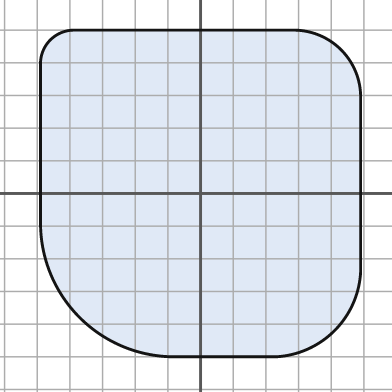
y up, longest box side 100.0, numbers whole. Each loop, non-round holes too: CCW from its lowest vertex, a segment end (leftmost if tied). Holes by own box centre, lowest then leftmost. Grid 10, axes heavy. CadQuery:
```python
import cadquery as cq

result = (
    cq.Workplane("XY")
    .moveTo(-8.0, -50.0)
    .lineTo(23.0, -50.0)
    .threePointArc((41.0, -42.0), (49.0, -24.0))
    .lineTo(49.0, 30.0)
    .threePointArc((43.0, 44.0), (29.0, 50.0))
    .lineTo(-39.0, 50.0)
    .threePointArc((-46.0, 47.0), (-49.0, 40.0))
    .lineTo(-49.0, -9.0)
    .threePointArc((-37.0, -38.0), (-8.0, -50.0))
    .close()
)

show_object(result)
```